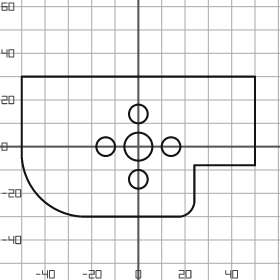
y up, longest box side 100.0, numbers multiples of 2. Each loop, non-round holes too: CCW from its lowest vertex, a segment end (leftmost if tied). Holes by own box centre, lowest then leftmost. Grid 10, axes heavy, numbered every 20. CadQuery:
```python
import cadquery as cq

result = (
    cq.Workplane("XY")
    .moveTo(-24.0, -30.0)
    .lineTo(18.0, -30.0)
    .threePointArc((22.0, -28.0), (24.0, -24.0))
    .lineTo(24.0, -8.0)
    .lineTo(50.0, -8.0)
    .lineTo(50.0, 30.0)
    .lineTo(-50.0, 30.0)
    .lineTo(-50.0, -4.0)
    .threePointArc((-42.0, -22.0), (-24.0, -30.0))
    .close()
    .moveTo(0.0, -14.0)
    .circle(4.0)
    .moveTo(-14.0, 0.0)
    .circle(4.0)
    .moveTo(0.0, 0.0)
    .circle(6.0)
    .moveTo(14.0, 0.0)
    .circle(4.0)
    .moveTo(0.0, 14.0)
    .circle(4.0)
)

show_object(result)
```